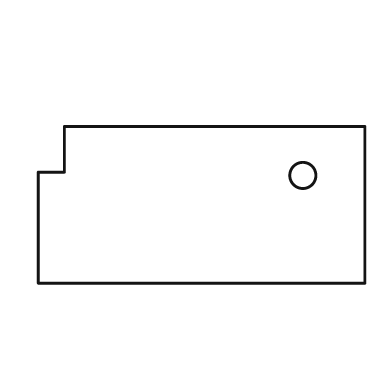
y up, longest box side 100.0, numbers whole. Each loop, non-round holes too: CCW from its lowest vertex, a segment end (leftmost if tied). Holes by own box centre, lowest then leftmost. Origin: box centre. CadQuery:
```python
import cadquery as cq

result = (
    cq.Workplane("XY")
    .moveTo(-50.0, -24.0)
    .lineTo(50.0, -24.0)
    .lineTo(50.0, 24.0)
    .lineTo(-42.0, 24.0)
    .lineTo(-42.0, 10.0)
    .lineTo(-50.0, 10.0)
    .close()
    .moveTo(31.0, 9.0)
    .circle(4.0)
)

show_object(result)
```